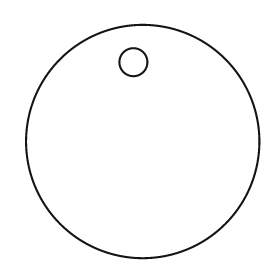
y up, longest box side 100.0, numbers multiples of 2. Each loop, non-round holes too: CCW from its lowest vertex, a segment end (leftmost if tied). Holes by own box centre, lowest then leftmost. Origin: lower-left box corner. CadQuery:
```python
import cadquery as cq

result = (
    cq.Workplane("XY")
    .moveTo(50.0, 50.0)
    .circle(50.0)
    .moveTo(46.0, 84.0)
    .circle(6.0)
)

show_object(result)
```